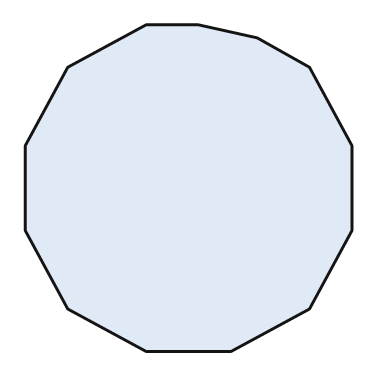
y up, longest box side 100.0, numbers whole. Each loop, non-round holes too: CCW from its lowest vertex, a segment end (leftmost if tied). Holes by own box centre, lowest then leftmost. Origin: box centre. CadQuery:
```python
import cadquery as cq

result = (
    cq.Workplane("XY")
    .moveTo(-13.0, -50.0)
    .lineTo(13.0, -50.0)
    .lineTo(37.0, -37.0)
    .lineTo(50.0, -13.0)
    .lineTo(50.0, 13.0)
    .lineTo(37.0, 37.0)
    .lineTo(21.0, 46.0)
    .lineTo(3.0, 50.0)
    .lineTo(-13.0, 50.0)
    .lineTo(-37.0, 37.0)
    .lineTo(-50.0, 13.0)
    .lineTo(-50.0, -13.0)
    .lineTo(-37.0, -37.0)
    .close()
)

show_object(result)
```